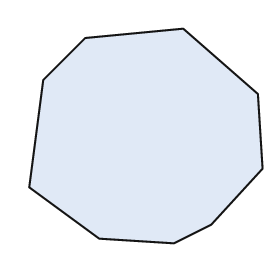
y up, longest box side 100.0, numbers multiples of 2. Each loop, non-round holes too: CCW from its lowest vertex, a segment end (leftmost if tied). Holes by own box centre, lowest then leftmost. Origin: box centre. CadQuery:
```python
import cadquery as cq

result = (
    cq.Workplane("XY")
    .moveTo(12.0, -46.0)
    .lineTo(28.0, -38.0)
    .lineTo(50.0, -14.0)
    .lineTo(48.0, 18.0)
    .lineTo(16.0, 46.0)
    .lineTo(-26.0, 42.0)
    .lineTo(-44.0, 24.0)
    .lineTo(-50.0, -22.0)
    .lineTo(-20.0, -44.0)
    .close()
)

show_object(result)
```